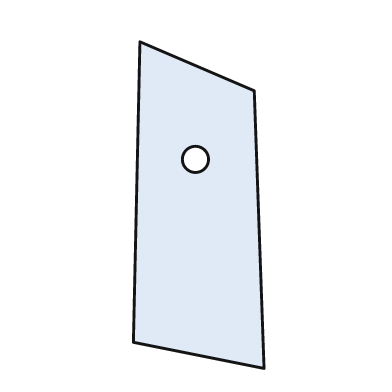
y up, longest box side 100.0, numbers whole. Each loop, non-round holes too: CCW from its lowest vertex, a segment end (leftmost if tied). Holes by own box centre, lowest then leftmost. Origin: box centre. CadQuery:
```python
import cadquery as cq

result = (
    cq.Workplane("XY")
    .moveTo(20.0, -50.0)
    .lineTo(17.0, 35.0)
    .lineTo(-18.0, 50.0)
    .lineTo(-20.0, -42.0)
    .close()
    .moveTo(-1.0, 14.0)
    .circle(4.0)
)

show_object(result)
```